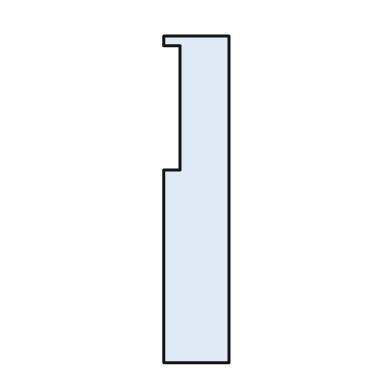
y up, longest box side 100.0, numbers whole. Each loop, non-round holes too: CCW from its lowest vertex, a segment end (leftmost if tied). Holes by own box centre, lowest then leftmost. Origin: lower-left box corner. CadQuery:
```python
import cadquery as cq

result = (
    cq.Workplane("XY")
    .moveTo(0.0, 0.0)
    .lineTo(20.0, 0.0)
    .lineTo(20.0, 100.0)
    .lineTo(0.0, 100.0)
    .lineTo(0.0, 97.0)
    .lineTo(5.0, 97.0)
    .lineTo(5.0, 59.0)
    .lineTo(0.0, 59.0)
    .close()
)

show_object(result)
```